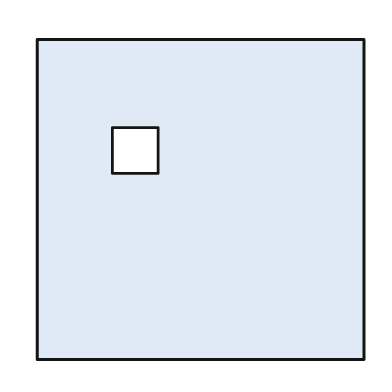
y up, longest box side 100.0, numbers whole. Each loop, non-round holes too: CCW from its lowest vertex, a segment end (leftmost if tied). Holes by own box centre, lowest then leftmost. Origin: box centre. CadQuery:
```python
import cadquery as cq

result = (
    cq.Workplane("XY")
    .moveTo(-50.0, -49.0)
    .lineTo(50.0, -49.0)
    .lineTo(50.0, 49.0)
    .lineTo(-50.0, 49.0)
    .close()
    .moveTo(-27.0, 8.0)
    .lineTo(-13.0, 8.0)
    .lineTo(-13.0, 22.0)
    .lineTo(-27.0, 22.0)
    .close()
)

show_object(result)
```